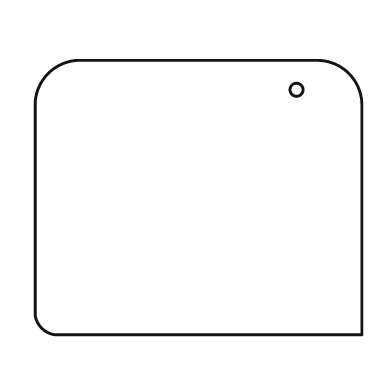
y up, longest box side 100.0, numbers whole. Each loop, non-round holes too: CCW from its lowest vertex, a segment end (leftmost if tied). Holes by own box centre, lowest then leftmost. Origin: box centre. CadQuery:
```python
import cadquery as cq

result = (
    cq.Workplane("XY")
    .moveTo(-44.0, -42.0)
    .lineTo(50.0, -42.0)
    .lineTo(50.0, 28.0)
    .threePointArc((46.0, 38.0), (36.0, 42.0))
    .lineTo(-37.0, 42.0)
    .threePointArc((-46.0, 38.0), (-50.0, 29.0))
    .lineTo(-50.0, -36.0)
    .threePointArc((-48.0, -40.0), (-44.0, -42.0))
    .close()
    .moveTo(30.0, 33.0)
    .circle(2.0)
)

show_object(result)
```